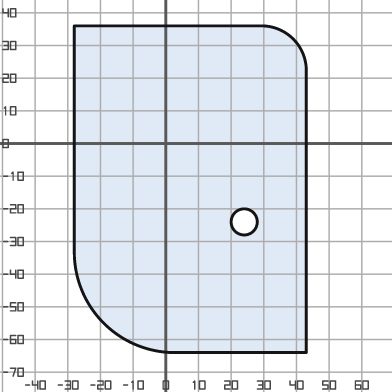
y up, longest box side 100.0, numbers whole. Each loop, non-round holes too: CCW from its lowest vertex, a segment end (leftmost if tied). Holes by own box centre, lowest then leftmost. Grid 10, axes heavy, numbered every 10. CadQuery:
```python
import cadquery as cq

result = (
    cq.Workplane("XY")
    .moveTo(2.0, -64.0)
    .lineTo(43.0, -64.0)
    .lineTo(43.0, 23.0)
    .threePointArc((39.0, 32.0), (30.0, 36.0))
    .lineTo(-28.0, 36.0)
    .lineTo(-28.0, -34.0)
    .threePointArc((-19.0, -55.0), (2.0, -64.0))
    .close()
    .moveTo(24.0, -24.0)
    .circle(4.0)
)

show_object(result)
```